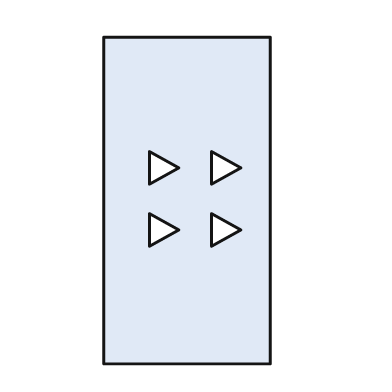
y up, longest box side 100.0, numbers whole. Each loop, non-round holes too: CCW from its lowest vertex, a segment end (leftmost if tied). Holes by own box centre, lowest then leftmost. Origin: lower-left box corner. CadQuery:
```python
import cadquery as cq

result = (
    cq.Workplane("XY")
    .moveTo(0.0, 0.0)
    .lineTo(51.0, 0.0)
    .lineTo(51.0, 100.0)
    .lineTo(0.0, 100.0)
    .close()
    .moveTo(14.0, 36.0)
    .lineTo(23.0, 41.0)
    .lineTo(14.0, 46.0)
    .close()
    .moveTo(33.0, 36.0)
    .lineTo(42.0, 41.0)
    .lineTo(33.0, 46.0)
    .close()
    .moveTo(14.0, 55.0)
    .lineTo(23.0, 60.0)
    .lineTo(14.0, 65.0)
    .close()
    .moveTo(33.0, 55.0)
    .lineTo(42.0, 60.0)
    .lineTo(33.0, 65.0)
    .close()
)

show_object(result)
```